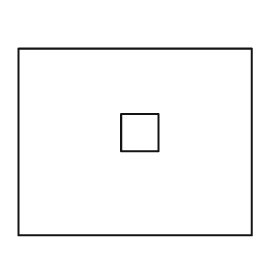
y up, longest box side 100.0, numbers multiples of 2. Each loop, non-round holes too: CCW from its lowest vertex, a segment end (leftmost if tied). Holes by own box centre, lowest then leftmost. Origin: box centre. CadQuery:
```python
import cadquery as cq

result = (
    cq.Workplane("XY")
    .moveTo(-50.0, -40.0)
    .lineTo(50.0, -40.0)
    .lineTo(50.0, 40.0)
    .lineTo(-50.0, 40.0)
    .close()
    .moveTo(-6.0, -4.0)
    .lineTo(10.0, -4.0)
    .lineTo(10.0, 12.0)
    .lineTo(-6.0, 12.0)
    .close()
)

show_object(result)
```